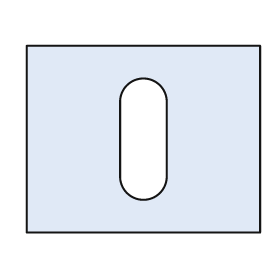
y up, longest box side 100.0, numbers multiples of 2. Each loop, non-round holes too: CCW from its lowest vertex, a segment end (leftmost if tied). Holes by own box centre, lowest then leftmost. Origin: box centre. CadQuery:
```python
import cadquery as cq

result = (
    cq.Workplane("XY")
    .moveTo(-50.0, -40.0)
    .lineTo(50.0, -40.0)
    .lineTo(50.0, 40.0)
    .lineTo(-50.0, 40.0)
    .close()
    .moveTo(-10.0, -16.0)
    .threePointArc((0.0, -26.0), (10.0, -16.0))
    .lineTo(10.0, 16.0)
    .threePointArc((0.0, 26.0), (-10.0, 16.0))
    .close()
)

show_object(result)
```